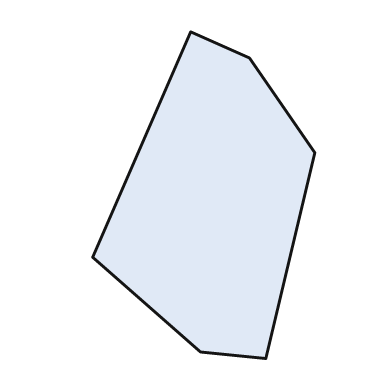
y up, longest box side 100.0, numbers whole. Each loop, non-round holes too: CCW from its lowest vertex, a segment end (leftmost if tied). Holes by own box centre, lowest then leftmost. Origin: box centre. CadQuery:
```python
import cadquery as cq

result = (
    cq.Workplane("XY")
    .moveTo(19.0, -50.0)
    .lineTo(34.0, 13.0)
    .lineTo(14.0, 42.0)
    .lineTo(-4.0, 50.0)
    .lineTo(-34.0, -19.0)
    .lineTo(-1.0, -48.0)
    .close()
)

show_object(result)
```